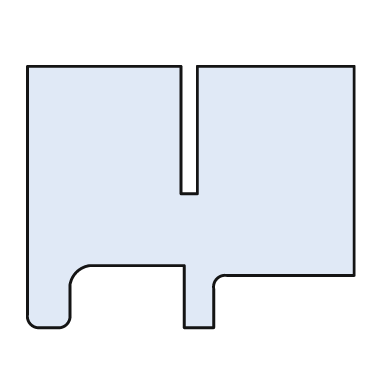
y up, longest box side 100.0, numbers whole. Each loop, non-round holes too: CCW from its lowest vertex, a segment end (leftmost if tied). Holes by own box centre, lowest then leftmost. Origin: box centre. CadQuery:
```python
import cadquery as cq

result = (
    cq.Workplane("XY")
    .moveTo(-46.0, -40.0)
    .lineTo(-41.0, -40.0)
    .threePointArc((-38.0, -39.0), (-37.0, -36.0))
    .lineTo(-37.0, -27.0)
    .threePointArc((-35.0, -23.0), (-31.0, -21.0))
    .lineTo(-2.0, -21.0)
    .lineTo(-2.0, -40.0)
    .lineTo(7.0, -40.0)
    .lineTo(7.0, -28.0)
    .threePointArc((8.0, -25.0), (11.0, -24.0))
    .lineTo(50.0, -24.0)
    .lineTo(50.0, 40.0)
    .lineTo(2.0, 40.0)
    .lineTo(2.0, 1.0)
    .lineTo(-3.0, 1.0)
    .lineTo(-3.0, 40.0)
    .lineTo(-50.0, 40.0)
    .lineTo(-50.0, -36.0)
    .threePointArc((-49.0, -39.0), (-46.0, -40.0))
    .close()
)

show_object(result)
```